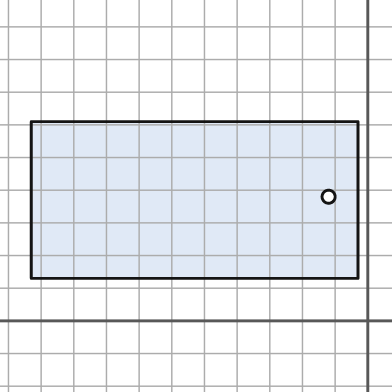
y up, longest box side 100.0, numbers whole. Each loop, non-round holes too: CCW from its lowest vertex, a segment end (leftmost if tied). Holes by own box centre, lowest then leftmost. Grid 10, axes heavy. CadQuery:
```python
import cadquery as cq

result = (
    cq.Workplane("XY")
    .moveTo(-103.0, 13.0)
    .lineTo(-3.0, 13.0)
    .lineTo(-3.0, 61.0)
    .lineTo(-103.0, 61.0)
    .close()
    .moveTo(-12.0, 38.0)
    .circle(2.0)
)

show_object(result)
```